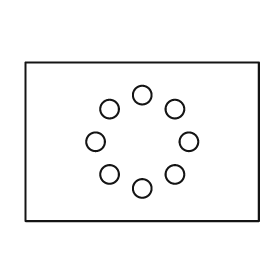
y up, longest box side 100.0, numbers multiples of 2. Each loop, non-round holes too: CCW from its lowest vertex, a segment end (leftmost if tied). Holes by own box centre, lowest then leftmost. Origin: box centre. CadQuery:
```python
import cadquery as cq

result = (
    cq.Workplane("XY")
    .moveTo(-50.0, -34.0)
    .lineTo(50.0, -34.0)
    .lineTo(50.0, 34.0)
    .lineTo(-50.0, 34.0)
    .close()
    .moveTo(0.0, -20.0)
    .circle(4.0)
    .moveTo(-14.0, -14.0)
    .circle(4.0)
    .moveTo(14.0, -14.0)
    .circle(4.0)
    .moveTo(-20.0, 0.0)
    .circle(4.0)
    .moveTo(20.0, 0.0)
    .circle(4.0)
    .moveTo(-14.0, 14.0)
    .circle(4.0)
    .moveTo(14.0, 14.0)
    .circle(4.0)
    .moveTo(0.0, 20.0)
    .circle(4.0)
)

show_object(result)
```